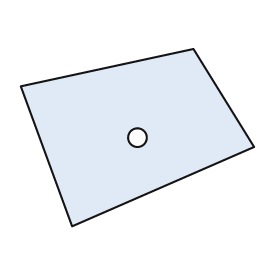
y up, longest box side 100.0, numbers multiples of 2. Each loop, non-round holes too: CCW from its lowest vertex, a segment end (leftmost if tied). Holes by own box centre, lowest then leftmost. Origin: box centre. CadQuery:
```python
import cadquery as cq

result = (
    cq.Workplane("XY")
    .moveTo(-28.0, -38.0)
    .lineTo(50.0, -4.0)
    .lineTo(24.0, 38.0)
    .lineTo(-50.0, 22.0)
    .close()
    .moveTo(0.0, 0.0)
    .circle(4.0)
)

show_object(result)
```